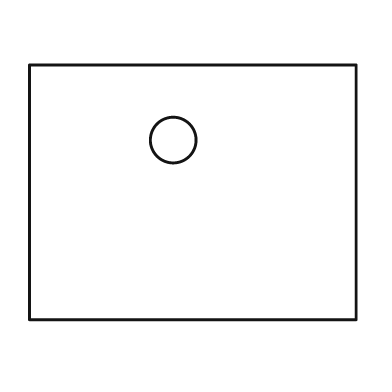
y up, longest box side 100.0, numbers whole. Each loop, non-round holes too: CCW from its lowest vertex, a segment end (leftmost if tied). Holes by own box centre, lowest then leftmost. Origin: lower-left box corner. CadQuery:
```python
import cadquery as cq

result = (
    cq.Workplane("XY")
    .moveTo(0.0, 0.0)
    .lineTo(100.0, 0.0)
    .lineTo(100.0, 78.0)
    .lineTo(0.0, 78.0)
    .close()
    .moveTo(44.0, 55.0)
    .circle(7.0)
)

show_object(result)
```